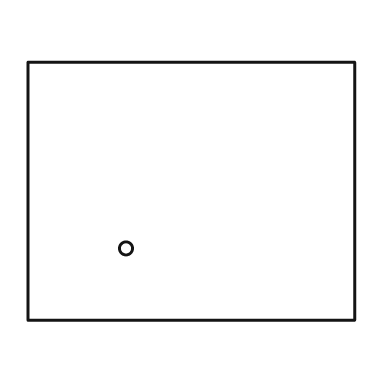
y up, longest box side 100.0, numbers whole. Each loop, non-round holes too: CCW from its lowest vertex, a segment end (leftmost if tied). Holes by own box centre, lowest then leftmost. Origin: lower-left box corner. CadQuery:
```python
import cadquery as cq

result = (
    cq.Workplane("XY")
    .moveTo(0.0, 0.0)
    .lineTo(100.0, 0.0)
    .lineTo(100.0, 79.0)
    .lineTo(0.0, 79.0)
    .close()
    .moveTo(30.0, 22.0)
    .circle(2.0)
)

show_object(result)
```